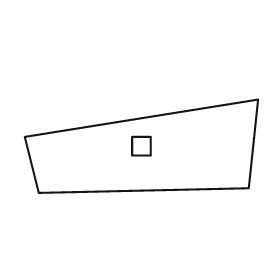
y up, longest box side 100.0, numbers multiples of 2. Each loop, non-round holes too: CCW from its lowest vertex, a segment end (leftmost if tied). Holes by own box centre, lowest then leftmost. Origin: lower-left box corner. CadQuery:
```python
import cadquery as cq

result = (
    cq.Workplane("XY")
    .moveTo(6.0, 0.0)
    .lineTo(96.0, 2.0)
    .lineTo(100.0, 40.0)
    .lineTo(0.0, 24.0)
    .close()
    .moveTo(46.0, 16.0)
    .lineTo(54.0, 16.0)
    .lineTo(54.0, 24.0)
    .lineTo(46.0, 24.0)
    .close()
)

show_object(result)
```